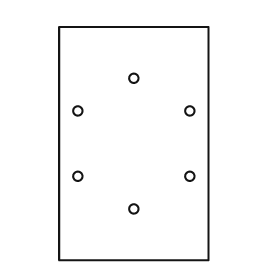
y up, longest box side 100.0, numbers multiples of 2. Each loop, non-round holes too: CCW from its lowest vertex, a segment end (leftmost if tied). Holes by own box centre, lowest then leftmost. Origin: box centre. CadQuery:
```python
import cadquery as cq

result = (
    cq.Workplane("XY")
    .moveTo(-32.0, -50.0)
    .lineTo(32.0, -50.0)
    .lineTo(32.0, 50.0)
    .lineTo(-32.0, 50.0)
    .close()
    .moveTo(0.0, -28.0)
    .circle(2.0)
    .moveTo(-24.0, -14.0)
    .circle(2.0)
    .moveTo(24.0, -14.0)
    .circle(2.0)
    .moveTo(-24.0, 14.0)
    .circle(2.0)
    .moveTo(24.0, 14.0)
    .circle(2.0)
    .moveTo(0.0, 28.0)
    .circle(2.0)
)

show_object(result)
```